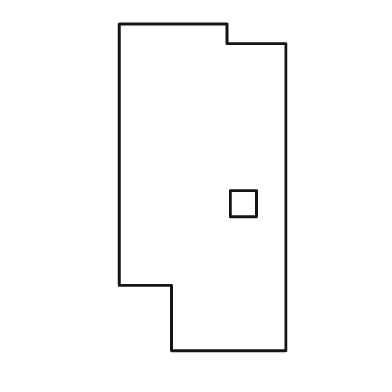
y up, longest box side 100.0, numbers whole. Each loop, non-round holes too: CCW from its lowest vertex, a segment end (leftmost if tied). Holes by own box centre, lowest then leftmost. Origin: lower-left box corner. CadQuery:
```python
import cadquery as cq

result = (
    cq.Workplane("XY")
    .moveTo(16.0, 0.0)
    .lineTo(51.0, 0.0)
    .lineTo(51.0, 94.0)
    .lineTo(33.0, 94.0)
    .lineTo(33.0, 100.0)
    .lineTo(0.0, 100.0)
    .lineTo(0.0, 20.0)
    .lineTo(16.0, 20.0)
    .close()
    .moveTo(34.0, 41.0)
    .lineTo(42.0, 41.0)
    .lineTo(42.0, 49.0)
    .lineTo(34.0, 49.0)
    .close()
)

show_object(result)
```